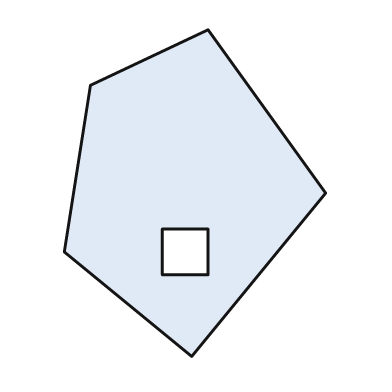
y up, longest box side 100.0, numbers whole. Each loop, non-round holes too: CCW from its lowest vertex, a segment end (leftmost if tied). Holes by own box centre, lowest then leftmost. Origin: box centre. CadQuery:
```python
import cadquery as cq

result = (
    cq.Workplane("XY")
    .moveTo(-1.0, -50.0)
    .lineTo(40.0, 0.0)
    .lineTo(4.0, 50.0)
    .lineTo(-32.0, 33.0)
    .lineTo(-40.0, -18.0)
    .close()
    .moveTo(-10.0, -25.0)
    .lineTo(4.0, -25.0)
    .lineTo(4.0, -11.0)
    .lineTo(-10.0, -11.0)
    .close()
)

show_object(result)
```